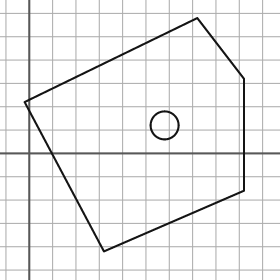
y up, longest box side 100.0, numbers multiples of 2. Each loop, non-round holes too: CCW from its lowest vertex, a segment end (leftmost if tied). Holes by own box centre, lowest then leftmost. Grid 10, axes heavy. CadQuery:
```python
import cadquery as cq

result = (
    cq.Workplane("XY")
    .moveTo(32.0, -42.0)
    .lineTo(92.0, -16.0)
    .lineTo(92.0, 32.0)
    .lineTo(72.0, 58.0)
    .lineTo(-2.0, 22.0)
    .close()
    .moveTo(58.0, 12.0)
    .circle(6.0)
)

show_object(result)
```